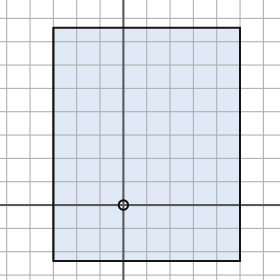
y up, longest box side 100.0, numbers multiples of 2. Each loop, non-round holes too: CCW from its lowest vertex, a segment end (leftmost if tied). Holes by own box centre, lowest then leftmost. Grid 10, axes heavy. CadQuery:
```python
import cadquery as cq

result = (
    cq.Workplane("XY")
    .moveTo(-30.0, -24.0)
    .lineTo(50.0, -24.0)
    .lineTo(50.0, 76.0)
    .lineTo(-30.0, 76.0)
    .close()
    .moveTo(0.0, 0.0)
    .circle(2.0)
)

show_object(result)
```